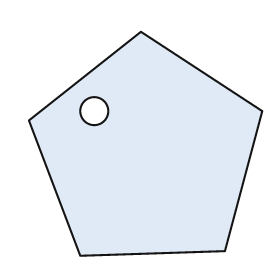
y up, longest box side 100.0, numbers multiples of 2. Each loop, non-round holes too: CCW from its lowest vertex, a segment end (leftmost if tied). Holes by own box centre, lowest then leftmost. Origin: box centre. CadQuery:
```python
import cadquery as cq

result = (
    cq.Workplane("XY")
    .moveTo(-28.0, -48.0)
    .lineTo(34.0, -46.0)
    .lineTo(50.0, 14.0)
    .lineTo(-2.0, 48.0)
    .lineTo(-50.0, 10.0)
    .close()
    .moveTo(-22.0, 14.0)
    .circle(6.0)
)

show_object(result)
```